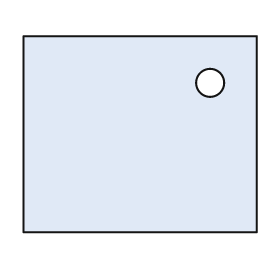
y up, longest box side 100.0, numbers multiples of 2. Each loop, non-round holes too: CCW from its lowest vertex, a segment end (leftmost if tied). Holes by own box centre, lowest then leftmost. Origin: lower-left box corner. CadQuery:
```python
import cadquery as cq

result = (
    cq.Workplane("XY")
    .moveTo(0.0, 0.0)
    .lineTo(100.0, 0.0)
    .lineTo(100.0, 84.0)
    .lineTo(0.0, 84.0)
    .close()
    .moveTo(80.0, 64.0)
    .circle(6.0)
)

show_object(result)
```